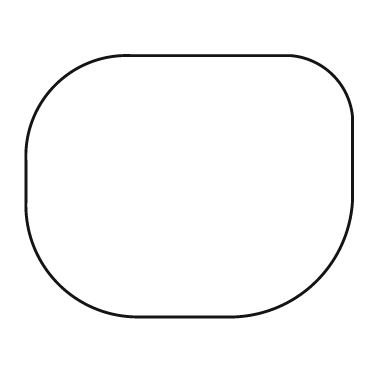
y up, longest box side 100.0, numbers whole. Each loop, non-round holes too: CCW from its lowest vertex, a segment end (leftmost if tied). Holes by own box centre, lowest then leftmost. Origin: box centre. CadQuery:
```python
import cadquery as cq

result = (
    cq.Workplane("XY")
    .moveTo(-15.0, -40.0)
    .lineTo(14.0, -40.0)
    .threePointArc((39.0, -29.0), (50.0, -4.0))
    .lineTo(50.0, 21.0)
    .threePointArc((44.0, 34.0), (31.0, 40.0))
    .lineTo(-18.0, 40.0)
    .threePointArc((-41.0, 31.0), (-50.0, 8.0))
    .lineTo(-50.0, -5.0)
    .threePointArc((-40.0, -30.0), (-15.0, -40.0))
    .close()
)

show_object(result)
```